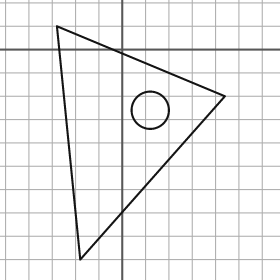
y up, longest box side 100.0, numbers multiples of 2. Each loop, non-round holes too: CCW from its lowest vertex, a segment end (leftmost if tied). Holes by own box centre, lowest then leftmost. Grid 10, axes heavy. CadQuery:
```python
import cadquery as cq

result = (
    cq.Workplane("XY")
    .moveTo(-18.0, -90.0)
    .lineTo(44.0, -20.0)
    .lineTo(-28.0, 10.0)
    .close()
    .moveTo(12.0, -26.0)
    .circle(8.0)
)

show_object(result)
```